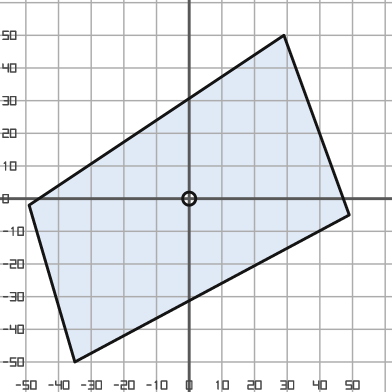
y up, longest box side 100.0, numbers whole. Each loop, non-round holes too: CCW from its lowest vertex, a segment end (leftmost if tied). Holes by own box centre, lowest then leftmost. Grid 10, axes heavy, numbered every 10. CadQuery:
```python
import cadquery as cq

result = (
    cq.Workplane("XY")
    .moveTo(-35.0, -50.0)
    .lineTo(49.0, -5.0)
    .lineTo(29.0, 50.0)
    .lineTo(-49.0, -2.0)
    .close()
    .moveTo(0.0, 0.0)
    .circle(2.0)
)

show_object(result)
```